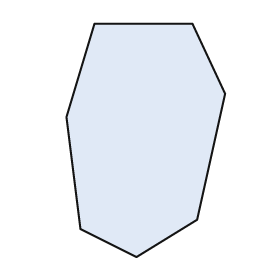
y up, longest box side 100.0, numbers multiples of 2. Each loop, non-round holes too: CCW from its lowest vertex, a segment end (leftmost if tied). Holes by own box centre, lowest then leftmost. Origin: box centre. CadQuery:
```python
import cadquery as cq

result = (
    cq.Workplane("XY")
    .moveTo(-4.0, -50.0)
    .lineTo(22.0, -34.0)
    .lineTo(34.0, 20.0)
    .lineTo(20.0, 50.0)
    .lineTo(-22.0, 50.0)
    .lineTo(-34.0, 10.0)
    .lineTo(-28.0, -38.0)
    .close()
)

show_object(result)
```